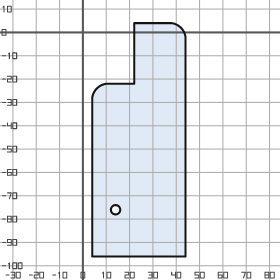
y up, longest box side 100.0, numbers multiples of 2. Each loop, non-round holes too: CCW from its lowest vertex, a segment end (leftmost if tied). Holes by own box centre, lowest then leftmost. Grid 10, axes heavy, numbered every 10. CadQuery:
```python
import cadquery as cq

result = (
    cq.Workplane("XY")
    .moveTo(4.0, -96.0)
    .lineTo(44.0, -96.0)
    .lineTo(44.0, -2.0)
    .threePointArc((42.0, 2.0), (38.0, 4.0))
    .lineTo(22.0, 4.0)
    .lineTo(22.0, -22.0)
    .lineTo(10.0, -22.0)
    .threePointArc((6.0, -24.0), (4.0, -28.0))
    .close()
    .moveTo(14.0, -76.0)
    .circle(2.0)
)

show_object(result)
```